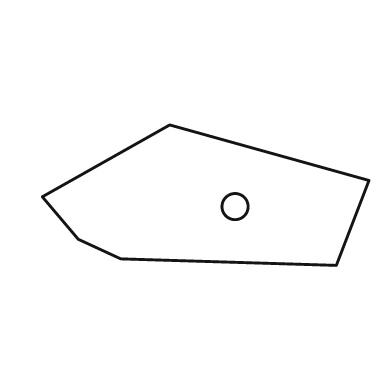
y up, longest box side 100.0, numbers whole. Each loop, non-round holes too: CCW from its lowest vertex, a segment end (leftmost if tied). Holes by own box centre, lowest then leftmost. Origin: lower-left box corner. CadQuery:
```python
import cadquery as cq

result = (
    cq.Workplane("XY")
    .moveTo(90.0, 0.0)
    .lineTo(100.0, 26.0)
    .lineTo(39.0, 43.0)
    .lineTo(0.0, 21.0)
    .lineTo(11.0, 8.0)
    .lineTo(24.0, 2.0)
    .close()
    .moveTo(59.0, 18.0)
    .circle(4.0)
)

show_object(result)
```